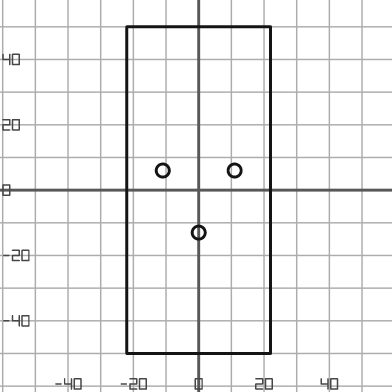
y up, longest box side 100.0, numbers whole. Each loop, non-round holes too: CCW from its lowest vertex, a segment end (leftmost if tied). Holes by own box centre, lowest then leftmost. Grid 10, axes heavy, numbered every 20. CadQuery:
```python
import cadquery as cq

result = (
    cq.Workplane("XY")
    .moveTo(-22.0, -50.0)
    .lineTo(22.0, -50.0)
    .lineTo(22.0, 50.0)
    .lineTo(-22.0, 50.0)
    .close()
    .moveTo(0.0, -13.0)
    .circle(2.0)
    .moveTo(-11.0, 6.0)
    .circle(2.0)
    .moveTo(11.0, 6.0)
    .circle(2.0)
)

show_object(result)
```